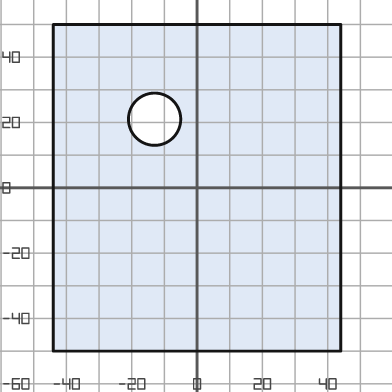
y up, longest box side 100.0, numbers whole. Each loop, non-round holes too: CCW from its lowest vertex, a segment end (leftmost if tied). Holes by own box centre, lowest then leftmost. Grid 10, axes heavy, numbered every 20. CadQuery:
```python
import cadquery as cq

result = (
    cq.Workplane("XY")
    .moveTo(-44.0, -50.0)
    .lineTo(44.0, -50.0)
    .lineTo(44.0, 50.0)
    .lineTo(-44.0, 50.0)
    .close()
    .moveTo(-13.0, 21.0)
    .circle(8.0)
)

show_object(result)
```